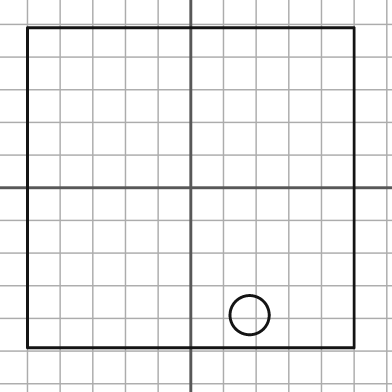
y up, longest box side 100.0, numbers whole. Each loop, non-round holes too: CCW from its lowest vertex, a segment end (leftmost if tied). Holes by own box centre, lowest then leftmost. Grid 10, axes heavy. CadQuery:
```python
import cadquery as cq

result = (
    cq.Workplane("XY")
    .moveTo(-50.0, -49.0)
    .lineTo(50.0, -49.0)
    .lineTo(50.0, 49.0)
    .lineTo(-50.0, 49.0)
    .close()
    .moveTo(18.0, -39.0)
    .circle(6.0)
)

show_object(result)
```